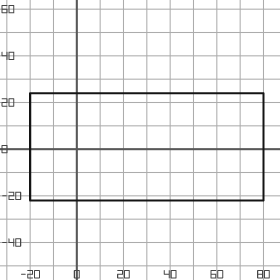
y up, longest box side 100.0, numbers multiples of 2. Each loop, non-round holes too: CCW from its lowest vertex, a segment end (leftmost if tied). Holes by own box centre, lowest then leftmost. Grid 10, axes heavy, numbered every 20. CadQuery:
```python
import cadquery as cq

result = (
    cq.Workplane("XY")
    .moveTo(-20.0, -22.0)
    .lineTo(80.0, -22.0)
    .lineTo(80.0, 24.0)
    .lineTo(-20.0, 24.0)
    .close()
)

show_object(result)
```